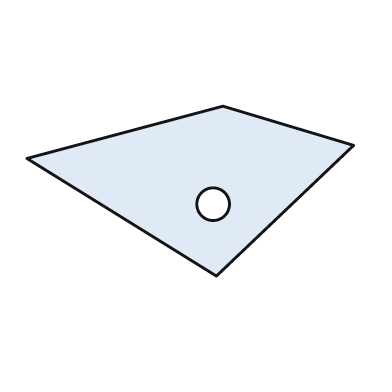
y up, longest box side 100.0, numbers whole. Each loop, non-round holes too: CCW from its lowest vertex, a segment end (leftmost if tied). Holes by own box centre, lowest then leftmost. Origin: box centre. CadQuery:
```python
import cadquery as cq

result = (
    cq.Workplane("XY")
    .moveTo(8.0, -26.0)
    .lineTo(50.0, 14.0)
    .lineTo(10.0, 26.0)
    .lineTo(-50.0, 10.0)
    .close()
    .moveTo(7.0, -4.0)
    .circle(5.0)
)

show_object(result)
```